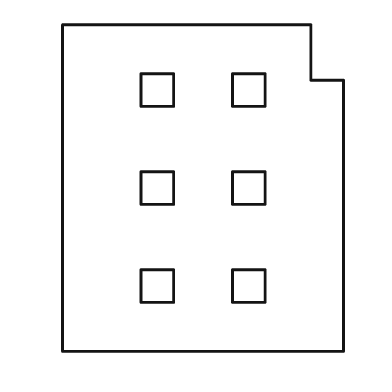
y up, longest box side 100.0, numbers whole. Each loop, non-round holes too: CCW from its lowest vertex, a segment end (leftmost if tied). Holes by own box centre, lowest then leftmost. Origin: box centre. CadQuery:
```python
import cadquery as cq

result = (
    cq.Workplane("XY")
    .moveTo(-43.0, -50.0)
    .lineTo(43.0, -50.0)
    .lineTo(43.0, 33.0)
    .lineTo(33.0, 33.0)
    .lineTo(33.0, 50.0)
    .lineTo(-43.0, 50.0)
    .close()
    .moveTo(-19.0, -35.0)
    .lineTo(-9.0, -35.0)
    .lineTo(-9.0, -25.0)
    .lineTo(-19.0, -25.0)
    .close()
    .moveTo(9.0, -35.0)
    .lineTo(19.0, -35.0)
    .lineTo(19.0, -25.0)
    .lineTo(9.0, -25.0)
    .close()
    .moveTo(-19.0, -5.0)
    .lineTo(-9.0, -5.0)
    .lineTo(-9.0, 5.0)
    .lineTo(-19.0, 5.0)
    .close()
    .moveTo(9.0, -5.0)
    .lineTo(19.0, -5.0)
    .lineTo(19.0, 5.0)
    .lineTo(9.0, 5.0)
    .close()
    .moveTo(-19.0, 25.0)
    .lineTo(-9.0, 25.0)
    .lineTo(-9.0, 35.0)
    .lineTo(-19.0, 35.0)
    .close()
    .moveTo(9.0, 25.0)
    .lineTo(19.0, 25.0)
    .lineTo(19.0, 35.0)
    .lineTo(9.0, 35.0)
    .close()
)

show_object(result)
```